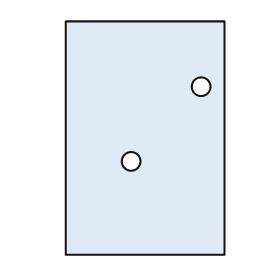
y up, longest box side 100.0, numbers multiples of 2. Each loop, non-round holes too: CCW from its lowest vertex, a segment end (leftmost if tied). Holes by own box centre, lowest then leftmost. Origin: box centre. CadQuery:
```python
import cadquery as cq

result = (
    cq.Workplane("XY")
    .moveTo(-34.0, -50.0)
    .lineTo(34.0, -50.0)
    .lineTo(34.0, 50.0)
    .lineTo(-34.0, 50.0)
    .close()
    .moveTo(-6.0, -10.0)
    .circle(4.0)
    .moveTo(24.0, 22.0)
    .circle(4.0)
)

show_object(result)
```